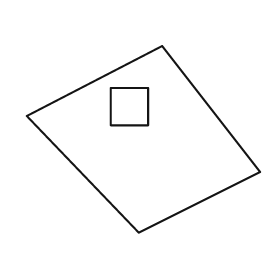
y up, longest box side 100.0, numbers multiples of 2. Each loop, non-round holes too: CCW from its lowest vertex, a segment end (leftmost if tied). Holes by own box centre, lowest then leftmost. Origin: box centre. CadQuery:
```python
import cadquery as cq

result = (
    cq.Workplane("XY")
    .moveTo(-2.0, -40.0)
    .lineTo(50.0, -14.0)
    .lineTo(8.0, 40.0)
    .lineTo(-50.0, 10.0)
    .close()
    .moveTo(-14.0, 6.0)
    .lineTo(2.0, 6.0)
    .lineTo(2.0, 22.0)
    .lineTo(-14.0, 22.0)
    .close()
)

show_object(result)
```